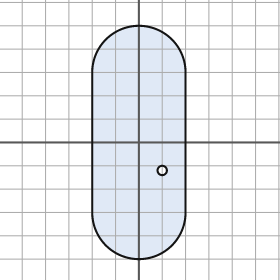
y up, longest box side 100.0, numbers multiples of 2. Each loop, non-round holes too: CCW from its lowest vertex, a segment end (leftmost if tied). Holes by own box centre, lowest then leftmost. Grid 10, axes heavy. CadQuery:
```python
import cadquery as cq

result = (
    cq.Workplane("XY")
    .moveTo(-20.0, -30.0)
    .threePointArc((0.0, -50.0), (20.0, -30.0))
    .lineTo(20.0, 30.0)
    .threePointArc((0.0, 50.0), (-20.0, 30.0))
    .close()
    .moveTo(10.0, -12.0)
    .circle(2.0)
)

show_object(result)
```